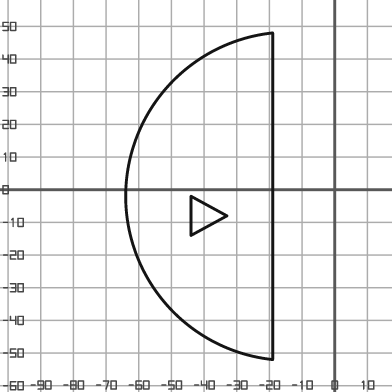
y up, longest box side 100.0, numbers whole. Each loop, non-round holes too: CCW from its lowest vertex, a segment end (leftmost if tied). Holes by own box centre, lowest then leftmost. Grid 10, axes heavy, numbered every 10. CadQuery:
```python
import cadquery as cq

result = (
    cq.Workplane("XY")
    .moveTo(-19.0, -52.0)
    .lineTo(-19.0, 48.0)
    .threePointArc((-64.0, -2.0), (-19.0, -52.0))
    .close()
    .moveTo(-44.0, -14.0)
    .lineTo(-33.0, -8.0)
    .lineTo(-44.0, -2.0)
    .close()
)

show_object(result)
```